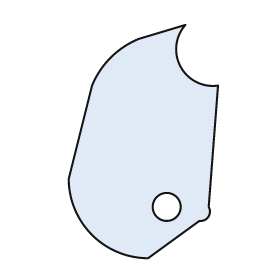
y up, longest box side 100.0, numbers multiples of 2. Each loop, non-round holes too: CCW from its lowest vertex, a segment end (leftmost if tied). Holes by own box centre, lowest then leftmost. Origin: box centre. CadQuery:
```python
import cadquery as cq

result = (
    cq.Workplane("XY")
    .moveTo(2.0, -50.0)
    .lineTo(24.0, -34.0)
    .threePointArc((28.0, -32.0), (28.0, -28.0))
    .lineTo(32.0, 24.0)
    .threePointArc((16.0, 32.0), (18.0, 50.0))
    .lineTo(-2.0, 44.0)
    .threePointArc((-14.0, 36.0), (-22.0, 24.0))
    .lineTo(-32.0, -16.0)
    .threePointArc((-22.0, -40.0), (2.0, -50.0))
    .close()
    .moveTo(10.0, -28.0)
    .circle(6.0)
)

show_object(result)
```